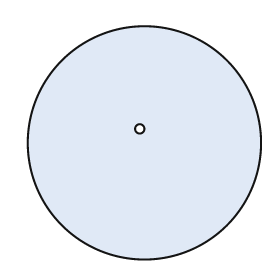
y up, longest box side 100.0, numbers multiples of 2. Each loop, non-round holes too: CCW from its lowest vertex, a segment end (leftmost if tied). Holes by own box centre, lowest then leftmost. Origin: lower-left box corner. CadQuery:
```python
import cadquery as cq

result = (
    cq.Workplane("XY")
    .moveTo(50.0, 50.0)
    .circle(50.0)
    .moveTo(48.0, 56.0)
    .circle(2.0)
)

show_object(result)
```